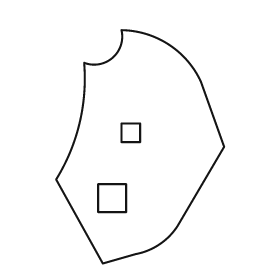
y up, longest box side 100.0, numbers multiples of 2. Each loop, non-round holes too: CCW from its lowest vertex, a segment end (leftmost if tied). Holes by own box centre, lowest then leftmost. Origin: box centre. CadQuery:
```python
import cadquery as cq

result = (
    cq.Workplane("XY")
    .moveTo(-16.0, -50.0)
    .lineTo(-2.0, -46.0)
    .threePointArc((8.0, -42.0), (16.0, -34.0))
    .lineTo(36.0, 0.0)
    .lineTo(26.0, 28.0)
    .threePointArc((12.0, 44.0), (-8.0, 50.0))
    .threePointArc((-12.0, 38.0), (-24.0, 36.0))
    .threePointArc((-26.0, 10.0), (-36.0, -14.0))
    .close()
    .moveTo(-18.0, -28.0)
    .lineTo(-6.0, -28.0)
    .lineTo(-6.0, -16.0)
    .lineTo(-18.0, -16.0)
    .close()
    .moveTo(-8.0, 2.0)
    .lineTo(0.0, 2.0)
    .lineTo(0.0, 10.0)
    .lineTo(-8.0, 10.0)
    .close()
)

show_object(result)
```